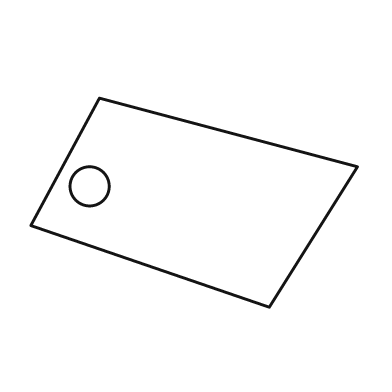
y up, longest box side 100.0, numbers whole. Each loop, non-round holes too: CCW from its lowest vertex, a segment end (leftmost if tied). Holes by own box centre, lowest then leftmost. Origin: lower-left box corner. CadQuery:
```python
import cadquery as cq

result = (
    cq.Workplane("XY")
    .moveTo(73.0, 0.0)
    .lineTo(100.0, 43.0)
    .lineTo(21.0, 64.0)
    .lineTo(0.0, 25.0)
    .close()
    .moveTo(18.0, 37.0)
    .circle(6.0)
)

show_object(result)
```